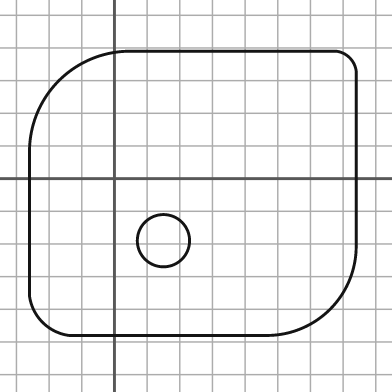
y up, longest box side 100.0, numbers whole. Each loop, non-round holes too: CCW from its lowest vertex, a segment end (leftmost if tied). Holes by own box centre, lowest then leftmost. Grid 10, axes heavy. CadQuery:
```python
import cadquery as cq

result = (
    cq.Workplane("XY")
    .moveTo(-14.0, -48.0)
    .lineTo(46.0, -48.0)
    .threePointArc((66.0, -40.0), (74.0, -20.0))
    .lineTo(74.0, 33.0)
    .threePointArc((72.0, 37.0), (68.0, 39.0))
    .lineTo(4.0, 39.0)
    .threePointArc((-17.0, 30.0), (-26.0, 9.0))
    .lineTo(-26.0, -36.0)
    .threePointArc((-22.0, -44.0), (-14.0, -48.0))
    .close()
    .moveTo(15.0, -19.0)
    .circle(8.0)
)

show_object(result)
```